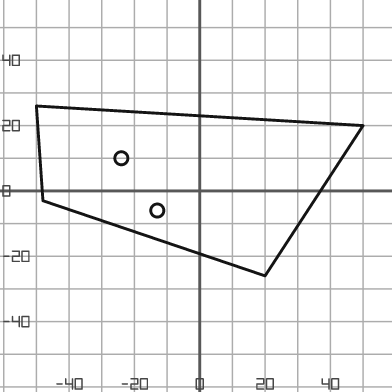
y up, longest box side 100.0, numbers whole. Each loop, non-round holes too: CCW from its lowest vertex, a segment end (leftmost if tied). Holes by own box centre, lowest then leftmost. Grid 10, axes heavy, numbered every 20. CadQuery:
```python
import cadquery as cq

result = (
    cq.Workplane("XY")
    .moveTo(20.0, -26.0)
    .lineTo(50.0, 20.0)
    .lineTo(-50.0, 26.0)
    .lineTo(-48.0, -3.0)
    .close()
    .moveTo(-13.0, -6.0)
    .circle(2.0)
    .moveTo(-24.0, 10.0)
    .circle(2.0)
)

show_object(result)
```